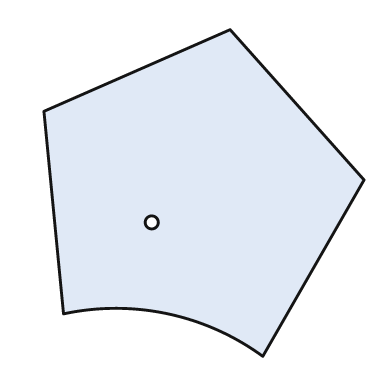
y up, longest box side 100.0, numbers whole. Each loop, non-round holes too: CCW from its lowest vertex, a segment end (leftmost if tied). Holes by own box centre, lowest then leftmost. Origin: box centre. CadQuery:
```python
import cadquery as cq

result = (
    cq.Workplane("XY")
    .moveTo(18.0, -50.0)
    .lineTo(49.0, 4.0)
    .lineTo(8.0, 50.0)
    .lineTo(-49.0, 25.0)
    .lineTo(-43.0, -37.0)
    .threePointArc((-11.0, -37.0), (18.0, -50.0))
    .close()
    .moveTo(-16.0, -9.0)
    .circle(2.0)
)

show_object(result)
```